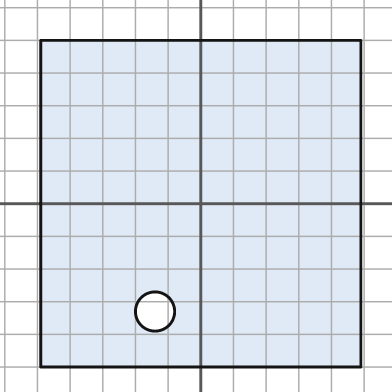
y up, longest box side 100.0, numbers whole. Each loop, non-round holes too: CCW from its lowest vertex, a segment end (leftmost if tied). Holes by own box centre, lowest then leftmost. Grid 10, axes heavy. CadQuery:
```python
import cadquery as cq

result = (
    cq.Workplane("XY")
    .moveTo(-49.0, -50.0)
    .lineTo(49.0, -50.0)
    .lineTo(49.0, 50.0)
    .lineTo(-49.0, 50.0)
    .close()
    .moveTo(-14.0, -33.0)
    .circle(6.0)
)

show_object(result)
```